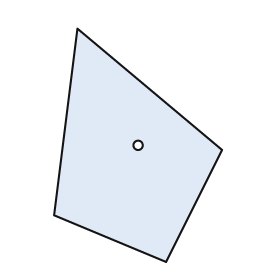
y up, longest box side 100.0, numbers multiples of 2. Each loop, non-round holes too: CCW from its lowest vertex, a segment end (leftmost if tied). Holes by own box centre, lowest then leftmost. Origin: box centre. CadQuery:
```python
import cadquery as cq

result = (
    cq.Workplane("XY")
    .moveTo(12.0, -50.0)
    .lineTo(36.0, -2.0)
    .lineTo(-26.0, 50.0)
    .lineTo(-36.0, -30.0)
    .close()
    .moveTo(0.0, 0.0)
    .circle(2.0)
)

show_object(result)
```